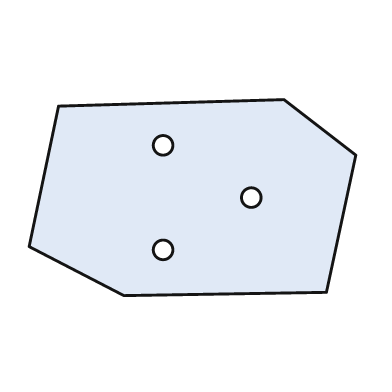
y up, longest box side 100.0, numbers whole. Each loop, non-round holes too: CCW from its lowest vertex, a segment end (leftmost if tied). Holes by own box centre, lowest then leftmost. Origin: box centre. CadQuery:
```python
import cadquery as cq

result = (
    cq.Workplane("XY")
    .moveTo(-21.0, -30.0)
    .lineTo(41.0, -29.0)
    .lineTo(50.0, 13.0)
    .lineTo(28.0, 30.0)
    .lineTo(-41.0, 28.0)
    .lineTo(-50.0, -15.0)
    .close()
    .moveTo(-9.0, -16.0)
    .circle(3.0)
    .moveTo(18.0, 0.0)
    .circle(3.0)
    .moveTo(-9.0, 16.0)
    .circle(3.0)
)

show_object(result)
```